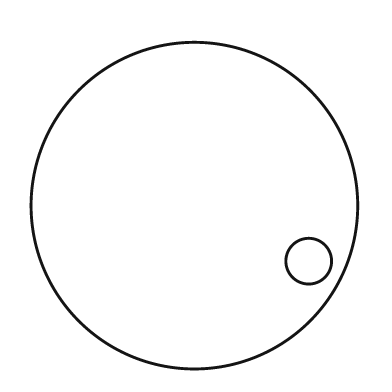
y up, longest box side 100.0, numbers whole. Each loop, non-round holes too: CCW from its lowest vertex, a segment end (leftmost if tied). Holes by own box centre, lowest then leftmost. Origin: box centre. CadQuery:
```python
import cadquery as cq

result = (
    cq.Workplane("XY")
    .moveTo(0.0, 0.0)
    .circle(50.0)
    .moveTo(35.0, -17.0)
    .circle(7.0)
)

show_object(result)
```